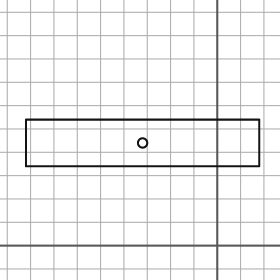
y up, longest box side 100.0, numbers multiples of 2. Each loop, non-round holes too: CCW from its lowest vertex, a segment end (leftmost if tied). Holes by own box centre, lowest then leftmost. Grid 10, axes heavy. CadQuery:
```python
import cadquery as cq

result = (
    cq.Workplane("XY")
    .moveTo(-82.0, 34.0)
    .lineTo(18.0, 34.0)
    .lineTo(18.0, 54.0)
    .lineTo(-82.0, 54.0)
    .close()
    .moveTo(-32.0, 44.0)
    .circle(2.0)
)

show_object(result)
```